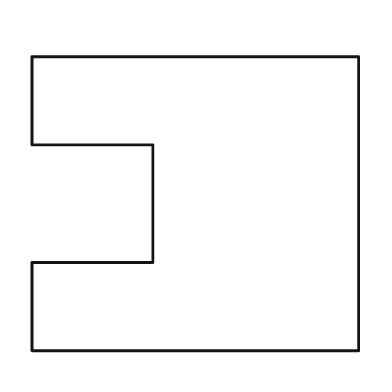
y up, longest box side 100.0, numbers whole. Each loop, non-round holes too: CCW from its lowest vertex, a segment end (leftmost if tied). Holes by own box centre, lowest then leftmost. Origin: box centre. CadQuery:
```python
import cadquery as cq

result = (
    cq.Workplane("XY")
    .moveTo(-50.0, -45.0)
    .lineTo(50.0, -45.0)
    .lineTo(50.0, 45.0)
    .lineTo(-50.0, 45.0)
    .lineTo(-50.0, 18.0)
    .lineTo(-13.0, 18.0)
    .lineTo(-13.0, -18.0)
    .lineTo(-50.0, -18.0)
    .close()
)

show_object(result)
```